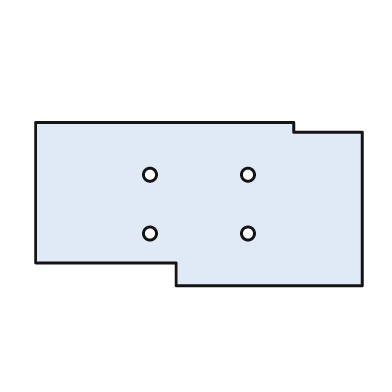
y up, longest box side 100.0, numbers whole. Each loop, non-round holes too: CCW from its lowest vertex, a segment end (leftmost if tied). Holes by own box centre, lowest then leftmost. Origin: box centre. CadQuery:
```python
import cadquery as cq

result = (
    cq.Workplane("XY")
    .moveTo(-7.0, -25.0)
    .lineTo(50.0, -25.0)
    .lineTo(50.0, 22.0)
    .lineTo(29.0, 22.0)
    .lineTo(29.0, 25.0)
    .lineTo(-50.0, 25.0)
    .lineTo(-50.0, -18.0)
    .lineTo(-7.0, -18.0)
    .close()
    .moveTo(-15.0, -9.0)
    .circle(2.0)
    .moveTo(15.0, -9.0)
    .circle(2.0)
    .moveTo(-15.0, 9.0)
    .circle(2.0)
    .moveTo(15.0, 9.0)
    .circle(2.0)
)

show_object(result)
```